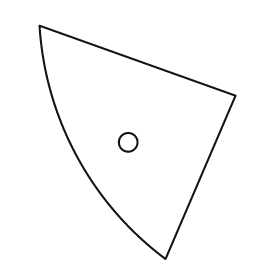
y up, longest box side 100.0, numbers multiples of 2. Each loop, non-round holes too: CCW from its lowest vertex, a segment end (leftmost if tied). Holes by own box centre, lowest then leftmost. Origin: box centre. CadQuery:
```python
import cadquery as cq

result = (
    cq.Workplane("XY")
    .moveTo(12.0, -50.0)
    .lineTo(42.0, 20.0)
    .lineTo(-42.0, 50.0)
    .threePointArc((-26.0, -6.0), (12.0, -50.0))
    .close()
    .moveTo(-4.0, 0.0)
    .circle(4.0)
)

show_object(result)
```